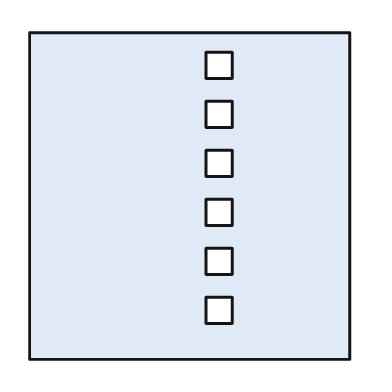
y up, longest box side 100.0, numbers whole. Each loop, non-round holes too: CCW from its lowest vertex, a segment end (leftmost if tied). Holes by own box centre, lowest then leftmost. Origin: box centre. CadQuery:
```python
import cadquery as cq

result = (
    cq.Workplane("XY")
    .moveTo(-49.0, -50.0)
    .lineTo(49.0, -50.0)
    .lineTo(49.0, 50.0)
    .lineTo(-49.0, 50.0)
    .close()
    .moveTo(5.0, -39.0)
    .lineTo(13.0, -39.0)
    .lineTo(13.0, -31.0)
    .lineTo(5.0, -31.0)
    .close()
    .moveTo(5.0, -24.0)
    .lineTo(13.0, -24.0)
    .lineTo(13.0, -16.0)
    .lineTo(5.0, -16.0)
    .close()
    .moveTo(5.0, -9.0)
    .lineTo(13.0, -9.0)
    .lineTo(13.0, -1.0)
    .lineTo(5.0, -1.0)
    .close()
    .moveTo(5.0, 6.0)
    .lineTo(13.0, 6.0)
    .lineTo(13.0, 14.0)
    .lineTo(5.0, 14.0)
    .close()
    .moveTo(5.0, 21.0)
    .lineTo(13.0, 21.0)
    .lineTo(13.0, 29.0)
    .lineTo(5.0, 29.0)
    .close()
    .moveTo(5.0, 36.0)
    .lineTo(13.0, 36.0)
    .lineTo(13.0, 44.0)
    .lineTo(5.0, 44.0)
    .close()
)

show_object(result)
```